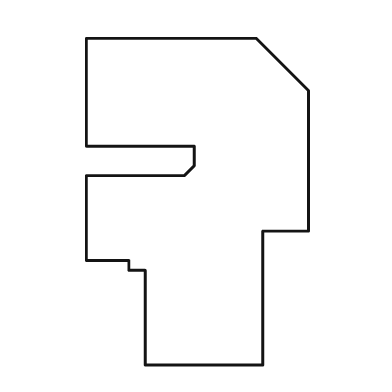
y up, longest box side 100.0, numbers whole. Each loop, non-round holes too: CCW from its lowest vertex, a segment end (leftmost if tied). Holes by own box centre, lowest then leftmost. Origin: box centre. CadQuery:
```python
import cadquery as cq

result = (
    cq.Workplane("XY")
    .moveTo(-16.0, -50.0)
    .lineTo(20.0, -50.0)
    .lineTo(20.0, -9.0)
    .lineTo(34.0, -9.0)
    .lineTo(34.0, 34.0)
    .lineTo(18.0, 50.0)
    .lineTo(-34.0, 50.0)
    .lineTo(-34.0, 17.0)
    .lineTo(-1.0, 17.0)
    .lineTo(-1.0, 11.0)
    .lineTo(-4.0, 8.0)
    .lineTo(-34.0, 8.0)
    .lineTo(-34.0, -18.0)
    .lineTo(-21.0, -18.0)
    .lineTo(-21.0, -21.0)
    .lineTo(-16.0, -21.0)
    .close()
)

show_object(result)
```